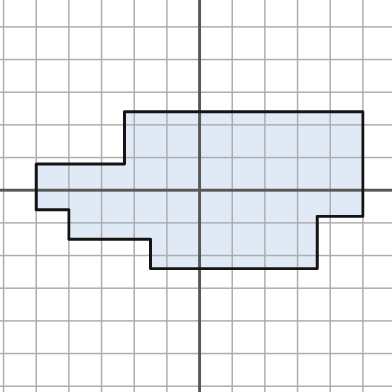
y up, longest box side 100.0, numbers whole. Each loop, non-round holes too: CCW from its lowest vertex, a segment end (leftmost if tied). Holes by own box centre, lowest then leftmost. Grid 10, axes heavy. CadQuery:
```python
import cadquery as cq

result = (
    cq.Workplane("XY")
    .moveTo(-15.0, -24.0)
    .lineTo(36.0, -24.0)
    .lineTo(36.0, -8.0)
    .lineTo(50.0, -8.0)
    .lineTo(50.0, 24.0)
    .lineTo(-23.0, 24.0)
    .lineTo(-23.0, 8.0)
    .lineTo(-50.0, 8.0)
    .lineTo(-50.0, -6.0)
    .lineTo(-40.0, -6.0)
    .lineTo(-40.0, -15.0)
    .lineTo(-15.0, -15.0)
    .close()
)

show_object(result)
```